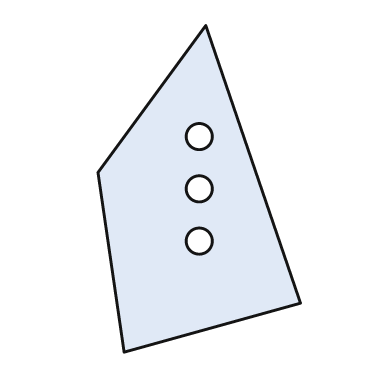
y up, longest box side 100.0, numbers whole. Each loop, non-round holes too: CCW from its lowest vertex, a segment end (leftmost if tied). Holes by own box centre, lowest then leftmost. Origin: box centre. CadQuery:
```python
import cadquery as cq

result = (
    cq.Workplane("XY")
    .moveTo(-23.0, -50.0)
    .lineTo(31.0, -35.0)
    .lineTo(2.0, 50.0)
    .lineTo(-31.0, 5.0)
    .close()
    .moveTo(0.0, -16.0)
    .circle(4.0)
    .moveTo(0.0, 0.0)
    .circle(4.0)
    .moveTo(0.0, 16.0)
    .circle(4.0)
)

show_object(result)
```